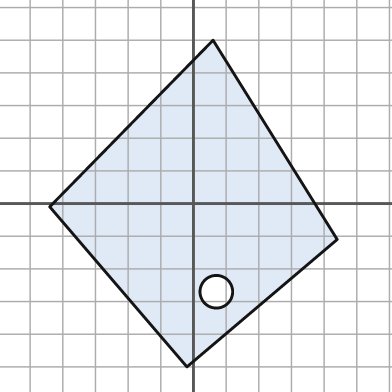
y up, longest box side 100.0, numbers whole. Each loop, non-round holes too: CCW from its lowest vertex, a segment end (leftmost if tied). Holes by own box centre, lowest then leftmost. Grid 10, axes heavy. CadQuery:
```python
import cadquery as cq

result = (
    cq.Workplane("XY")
    .moveTo(-2.0, -50.0)
    .lineTo(44.0, -11.0)
    .lineTo(6.0, 50.0)
    .lineTo(-44.0, -1.0)
    .close()
    .moveTo(7.0, -27.0)
    .circle(5.0)
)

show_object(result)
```